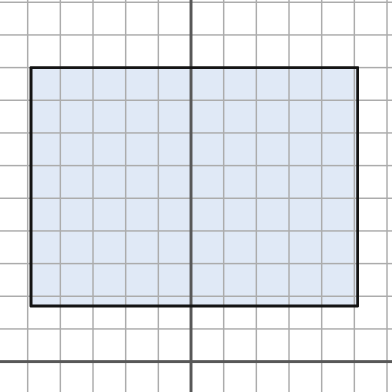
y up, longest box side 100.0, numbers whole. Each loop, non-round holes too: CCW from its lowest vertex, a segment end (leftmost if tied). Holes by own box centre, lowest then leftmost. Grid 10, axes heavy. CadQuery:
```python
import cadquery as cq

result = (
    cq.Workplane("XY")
    .moveTo(-49.0, 17.0)
    .lineTo(51.0, 17.0)
    .lineTo(51.0, 90.0)
    .lineTo(-49.0, 90.0)
    .close()
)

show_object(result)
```